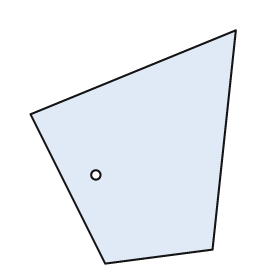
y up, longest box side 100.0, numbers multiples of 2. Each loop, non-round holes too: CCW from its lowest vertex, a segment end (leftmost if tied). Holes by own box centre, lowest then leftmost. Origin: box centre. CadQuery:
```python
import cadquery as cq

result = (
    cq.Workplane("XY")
    .moveTo(-12.0, -50.0)
    .lineTo(34.0, -44.0)
    .lineTo(44.0, 50.0)
    .lineTo(-44.0, 14.0)
    .close()
    .moveTo(-16.0, -12.0)
    .circle(2.0)
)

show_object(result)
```